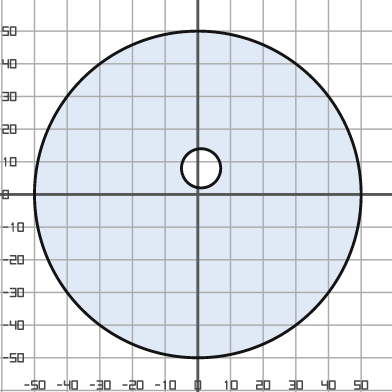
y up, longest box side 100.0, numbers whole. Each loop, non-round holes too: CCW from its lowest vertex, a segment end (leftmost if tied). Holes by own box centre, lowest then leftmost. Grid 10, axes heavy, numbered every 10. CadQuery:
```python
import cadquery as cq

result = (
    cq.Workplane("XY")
    .moveTo(0.0, 0.0)
    .circle(50.0)
    .moveTo(1.0, 8.0)
    .circle(6.0)
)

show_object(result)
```